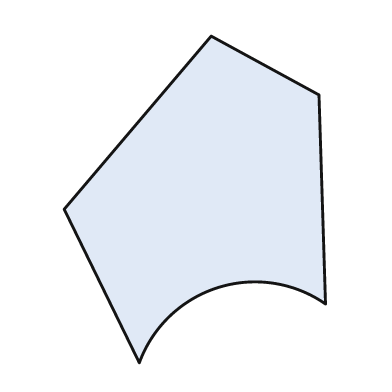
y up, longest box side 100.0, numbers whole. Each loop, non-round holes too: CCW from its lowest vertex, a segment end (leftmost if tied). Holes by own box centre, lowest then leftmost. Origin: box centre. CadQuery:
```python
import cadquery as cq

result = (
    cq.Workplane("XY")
    .moveTo(-17.0, -50.0)
    .threePointArc((7.0, -27.0), (40.0, -32.0))
    .lineTo(38.0, 32.0)
    .lineTo(5.0, 50.0)
    .lineTo(-40.0, -3.0)
    .close()
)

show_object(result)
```